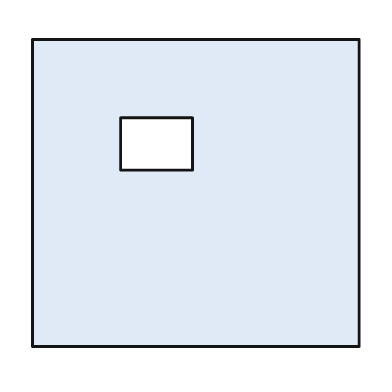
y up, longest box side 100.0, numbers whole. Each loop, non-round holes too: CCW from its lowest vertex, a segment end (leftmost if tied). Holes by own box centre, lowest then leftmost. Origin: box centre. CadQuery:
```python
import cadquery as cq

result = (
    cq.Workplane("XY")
    .moveTo(-50.0, -47.0)
    .lineTo(50.0, -47.0)
    .lineTo(50.0, 47.0)
    .lineTo(-50.0, 47.0)
    .close()
    .moveTo(-23.0, 7.0)
    .lineTo(-1.0, 7.0)
    .lineTo(-1.0, 23.0)
    .lineTo(-23.0, 23.0)
    .close()
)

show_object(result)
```